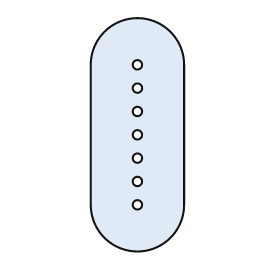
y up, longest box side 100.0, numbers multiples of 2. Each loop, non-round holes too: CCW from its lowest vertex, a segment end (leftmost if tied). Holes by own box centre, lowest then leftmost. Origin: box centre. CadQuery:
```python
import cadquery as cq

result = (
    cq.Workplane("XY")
    .moveTo(-20.0, -30.0)
    .threePointArc((0.0, -50.0), (20.0, -30.0))
    .lineTo(20.0, 30.0)
    .threePointArc((0.0, 50.0), (-20.0, 30.0))
    .close()
    .moveTo(0.0, -30.0)
    .circle(2.0)
    .moveTo(0.0, -20.0)
    .circle(2.0)
    .moveTo(0.0, -10.0)
    .circle(2.0)
    .moveTo(0.0, 0.0)
    .circle(2.0)
    .moveTo(0.0, 10.0)
    .circle(2.0)
    .moveTo(0.0, 20.0)
    .circle(2.0)
    .moveTo(0.0, 30.0)
    .circle(2.0)
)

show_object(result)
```